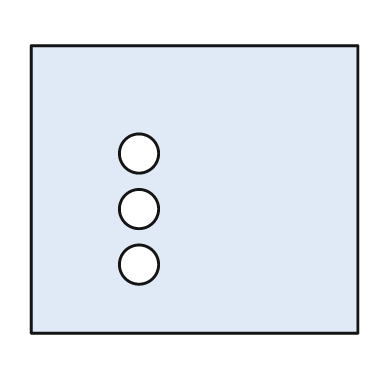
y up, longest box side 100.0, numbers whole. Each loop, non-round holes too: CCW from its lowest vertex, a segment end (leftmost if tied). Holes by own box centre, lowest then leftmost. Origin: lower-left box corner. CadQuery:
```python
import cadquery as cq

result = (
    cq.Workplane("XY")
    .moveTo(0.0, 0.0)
    .lineTo(100.0, 0.0)
    .lineTo(100.0, 88.0)
    .lineTo(0.0, 88.0)
    .close()
    .moveTo(33.0, 21.0)
    .circle(6.0)
    .moveTo(33.0, 38.0)
    .circle(6.0)
    .moveTo(33.0, 55.0)
    .circle(6.0)
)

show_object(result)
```